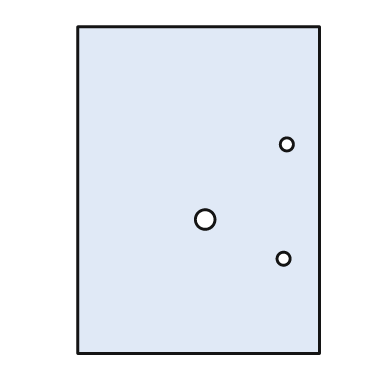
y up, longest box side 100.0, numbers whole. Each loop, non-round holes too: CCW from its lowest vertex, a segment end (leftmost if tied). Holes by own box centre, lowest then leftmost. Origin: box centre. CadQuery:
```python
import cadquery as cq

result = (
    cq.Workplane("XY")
    .moveTo(-37.0, -50.0)
    .lineTo(37.0, -50.0)
    .lineTo(37.0, 50.0)
    .lineTo(-37.0, 50.0)
    .close()
    .moveTo(26.0, -21.0)
    .circle(2.0)
    .moveTo(2.0, -9.0)
    .circle(3.0)
    .moveTo(27.0, 14.0)
    .circle(2.0)
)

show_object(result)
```